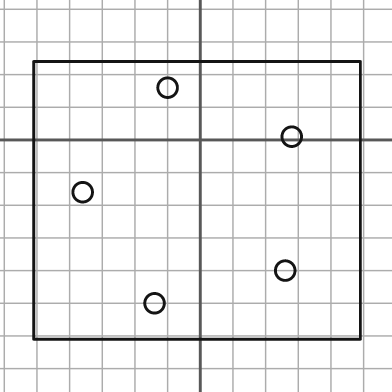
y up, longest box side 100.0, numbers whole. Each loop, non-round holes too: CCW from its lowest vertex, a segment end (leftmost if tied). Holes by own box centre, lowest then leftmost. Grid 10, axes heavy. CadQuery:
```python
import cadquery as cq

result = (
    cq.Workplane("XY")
    .moveTo(-51.0, -61.0)
    .lineTo(49.0, -61.0)
    .lineTo(49.0, 24.0)
    .lineTo(-51.0, 24.0)
    .close()
    .moveTo(-14.0, -50.0)
    .circle(3.0)
    .moveTo(26.0, -40.0)
    .circle(3.0)
    .moveTo(-36.0, -16.0)
    .circle(3.0)
    .moveTo(28.0, 1.0)
    .circle(3.0)
    .moveTo(-10.0, 16.0)
    .circle(3.0)
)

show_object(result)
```